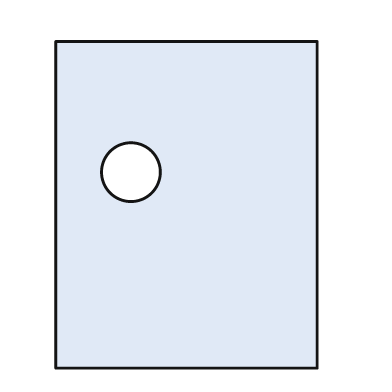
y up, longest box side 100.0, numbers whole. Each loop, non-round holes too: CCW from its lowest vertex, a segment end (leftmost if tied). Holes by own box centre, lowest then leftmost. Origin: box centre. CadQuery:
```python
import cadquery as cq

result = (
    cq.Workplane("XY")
    .moveTo(-40.0, -50.0)
    .lineTo(40.0, -50.0)
    .lineTo(40.0, 50.0)
    .lineTo(-40.0, 50.0)
    .close()
    .moveTo(-17.0, 10.0)
    .circle(9.0)
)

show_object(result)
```